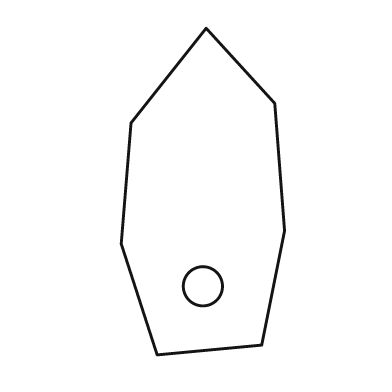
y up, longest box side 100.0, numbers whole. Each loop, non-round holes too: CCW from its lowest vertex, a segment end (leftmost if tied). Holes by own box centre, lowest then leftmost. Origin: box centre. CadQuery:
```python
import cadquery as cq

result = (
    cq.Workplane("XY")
    .moveTo(-14.0, -50.0)
    .lineTo(18.0, -47.0)
    .lineTo(25.0, -12.0)
    .lineTo(22.0, 27.0)
    .lineTo(1.0, 50.0)
    .lineTo(-22.0, 21.0)
    .lineTo(-25.0, -16.0)
    .close()
    .moveTo(0.0, -29.0)
    .circle(6.0)
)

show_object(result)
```